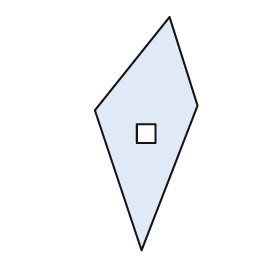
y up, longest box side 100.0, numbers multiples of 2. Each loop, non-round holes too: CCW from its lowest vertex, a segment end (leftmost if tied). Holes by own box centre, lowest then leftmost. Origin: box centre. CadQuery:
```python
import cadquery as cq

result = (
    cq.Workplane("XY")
    .moveTo(-2.0, -50.0)
    .lineTo(22.0, 12.0)
    .lineTo(10.0, 50.0)
    .lineTo(-22.0, 10.0)
    .close()
    .moveTo(-4.0, -4.0)
    .lineTo(4.0, -4.0)
    .lineTo(4.0, 4.0)
    .lineTo(-4.0, 4.0)
    .close()
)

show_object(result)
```